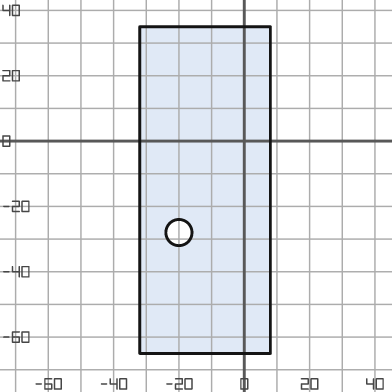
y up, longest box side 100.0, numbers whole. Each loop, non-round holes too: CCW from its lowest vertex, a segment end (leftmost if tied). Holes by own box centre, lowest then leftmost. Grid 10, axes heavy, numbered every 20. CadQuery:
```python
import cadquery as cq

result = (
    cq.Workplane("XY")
    .moveTo(-32.0, -65.0)
    .lineTo(8.0, -65.0)
    .lineTo(8.0, 35.0)
    .lineTo(-32.0, 35.0)
    .close()
    .moveTo(-20.0, -28.0)
    .circle(4.0)
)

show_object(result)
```